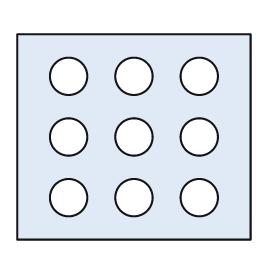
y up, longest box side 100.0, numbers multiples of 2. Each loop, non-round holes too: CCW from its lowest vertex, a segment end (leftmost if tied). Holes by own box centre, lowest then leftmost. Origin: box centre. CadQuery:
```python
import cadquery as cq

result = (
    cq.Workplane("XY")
    .moveTo(-50.0, -44.0)
    .lineTo(50.0, -44.0)
    .lineTo(50.0, 44.0)
    .lineTo(-50.0, 44.0)
    .close()
    .moveTo(-28.0, -26.0)
    .circle(8.0)
    .moveTo(0.0, -26.0)
    .circle(8.0)
    .moveTo(28.0, -26.0)
    .circle(8.0)
    .moveTo(-28.0, 0.0)
    .circle(8.0)
    .moveTo(0.0, 0.0)
    .circle(8.0)
    .moveTo(28.0, 0.0)
    .circle(8.0)
    .moveTo(-28.0, 26.0)
    .circle(8.0)
    .moveTo(0.0, 26.0)
    .circle(8.0)
    .moveTo(28.0, 26.0)
    .circle(8.0)
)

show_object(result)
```